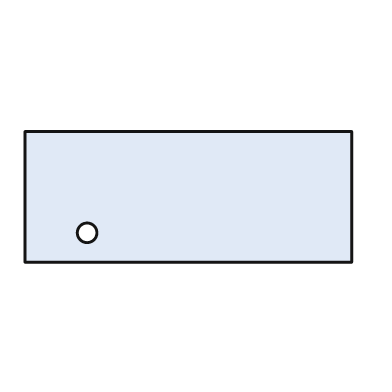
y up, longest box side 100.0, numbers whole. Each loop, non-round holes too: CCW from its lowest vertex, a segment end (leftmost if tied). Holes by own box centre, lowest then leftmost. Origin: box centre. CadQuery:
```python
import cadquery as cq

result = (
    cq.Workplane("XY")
    .moveTo(-50.0, -20.0)
    .lineTo(50.0, -20.0)
    .lineTo(50.0, 20.0)
    .lineTo(-50.0, 20.0)
    .close()
    .moveTo(-31.0, -11.0)
    .circle(3.0)
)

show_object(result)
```